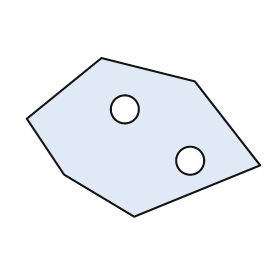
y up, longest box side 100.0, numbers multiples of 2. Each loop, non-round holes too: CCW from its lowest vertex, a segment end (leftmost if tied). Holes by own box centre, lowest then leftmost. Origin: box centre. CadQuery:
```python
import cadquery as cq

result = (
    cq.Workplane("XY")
    .moveTo(-4.0, -34.0)
    .lineTo(50.0, -12.0)
    .lineTo(22.0, 24.0)
    .lineTo(-18.0, 34.0)
    .lineTo(-50.0, 8.0)
    .lineTo(-34.0, -16.0)
    .close()
    .moveTo(20.0, -10.0)
    .circle(6.0)
    .moveTo(-8.0, 12.0)
    .circle(6.0)
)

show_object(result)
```